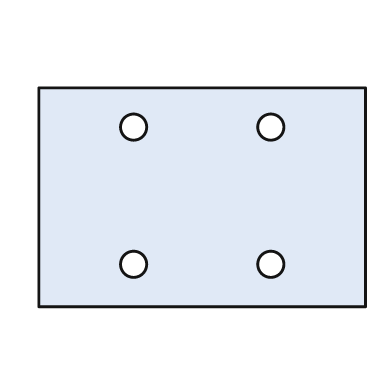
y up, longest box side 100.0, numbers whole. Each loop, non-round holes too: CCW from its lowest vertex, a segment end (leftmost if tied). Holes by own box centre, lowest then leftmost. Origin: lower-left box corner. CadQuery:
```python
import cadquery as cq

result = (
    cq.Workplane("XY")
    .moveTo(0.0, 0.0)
    .lineTo(100.0, 0.0)
    .lineTo(100.0, 67.0)
    .lineTo(0.0, 67.0)
    .close()
    .moveTo(29.0, 13.0)
    .circle(4.0)
    .moveTo(71.0, 13.0)
    .circle(4.0)
    .moveTo(29.0, 55.0)
    .circle(4.0)
    .moveTo(71.0, 55.0)
    .circle(4.0)
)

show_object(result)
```